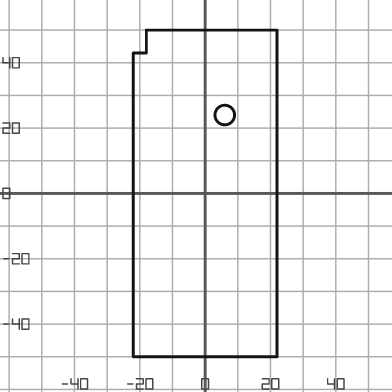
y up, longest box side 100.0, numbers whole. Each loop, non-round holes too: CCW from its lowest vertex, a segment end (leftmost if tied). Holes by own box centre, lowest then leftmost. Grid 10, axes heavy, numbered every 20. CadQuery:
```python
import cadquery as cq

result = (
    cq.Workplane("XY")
    .moveTo(-22.0, -50.0)
    .lineTo(22.0, -50.0)
    .lineTo(22.0, 50.0)
    .lineTo(-18.0, 50.0)
    .lineTo(-18.0, 43.0)
    .lineTo(-22.0, 43.0)
    .close()
    .moveTo(6.0, 24.0)
    .circle(3.0)
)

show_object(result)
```